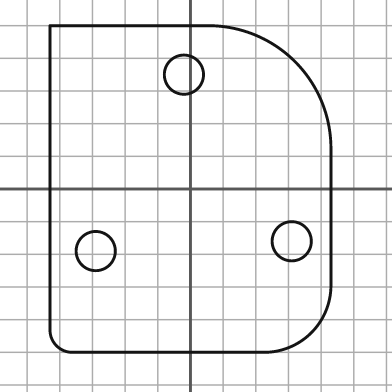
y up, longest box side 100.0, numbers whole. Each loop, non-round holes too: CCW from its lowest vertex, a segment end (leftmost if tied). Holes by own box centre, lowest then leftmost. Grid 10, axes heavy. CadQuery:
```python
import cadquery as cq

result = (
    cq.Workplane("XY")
    .moveTo(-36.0, -50.0)
    .lineTo(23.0, -50.0)
    .threePointArc((37.0, -44.0), (43.0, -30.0))
    .lineTo(43.0, 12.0)
    .threePointArc((32.0, 39.0), (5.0, 50.0))
    .lineTo(-43.0, 50.0)
    .lineTo(-43.0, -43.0)
    .threePointArc((-41.0, -48.0), (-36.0, -50.0))
    .close()
    .moveTo(-29.0, -19.0)
    .circle(6.0)
    .moveTo(31.0, -16.0)
    .circle(6.0)
    .moveTo(-2.0, 35.0)
    .circle(6.0)
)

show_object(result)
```